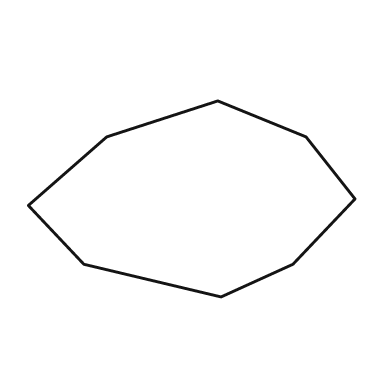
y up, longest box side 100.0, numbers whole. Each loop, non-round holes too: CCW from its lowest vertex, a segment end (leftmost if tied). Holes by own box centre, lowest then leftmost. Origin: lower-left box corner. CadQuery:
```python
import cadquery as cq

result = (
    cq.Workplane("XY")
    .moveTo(59.0, 0.0)
    .lineTo(81.0, 10.0)
    .lineTo(100.0, 30.0)
    .lineTo(85.0, 49.0)
    .lineTo(58.0, 60.0)
    .lineTo(24.0, 49.0)
    .lineTo(0.0, 28.0)
    .lineTo(17.0, 10.0)
    .close()
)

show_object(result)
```